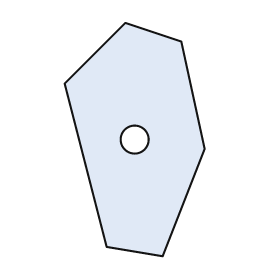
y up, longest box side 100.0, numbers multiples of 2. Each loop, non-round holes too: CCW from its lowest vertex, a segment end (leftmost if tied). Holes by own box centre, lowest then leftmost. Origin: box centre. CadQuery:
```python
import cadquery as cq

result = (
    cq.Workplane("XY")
    .moveTo(12.0, -50.0)
    .lineTo(30.0, -4.0)
    .lineTo(20.0, 42.0)
    .lineTo(-4.0, 50.0)
    .lineTo(-30.0, 24.0)
    .lineTo(-12.0, -46.0)
    .close()
    .moveTo(0.0, 0.0)
    .circle(6.0)
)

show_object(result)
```